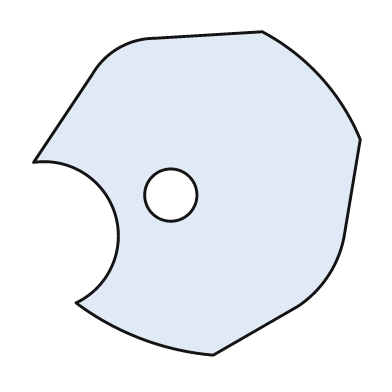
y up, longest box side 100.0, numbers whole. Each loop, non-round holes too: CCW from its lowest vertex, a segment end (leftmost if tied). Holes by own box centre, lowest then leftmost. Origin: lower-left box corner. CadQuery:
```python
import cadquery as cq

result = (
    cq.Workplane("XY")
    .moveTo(55.0, 0.0)
    .lineTo(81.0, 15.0)
    .threePointArc((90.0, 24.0), (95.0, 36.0))
    .lineTo(100.0, 66.0)
    .threePointArc((88.0, 85.0), (70.0, 99.0))
    .lineTo(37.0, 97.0)
    .threePointArc((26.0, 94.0), (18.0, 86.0))
    .lineTo(0.0, 59.0)
    .threePointArc((25.0, 43.0), (13.0, 16.0))
    .threePointArc((33.0, 5.0), (55.0, 0.0))
    .close()
    .moveTo(42.0, 49.0)
    .circle(8.0)
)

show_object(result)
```